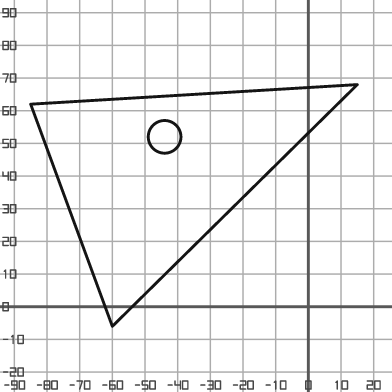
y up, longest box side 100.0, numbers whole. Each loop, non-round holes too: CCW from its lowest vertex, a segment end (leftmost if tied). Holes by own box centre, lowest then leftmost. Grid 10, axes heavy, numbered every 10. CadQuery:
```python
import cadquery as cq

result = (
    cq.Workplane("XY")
    .moveTo(-60.0, -6.0)
    .lineTo(15.0, 68.0)
    .lineTo(-85.0, 62.0)
    .close()
    .moveTo(-44.0, 52.0)
    .circle(5.0)
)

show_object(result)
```